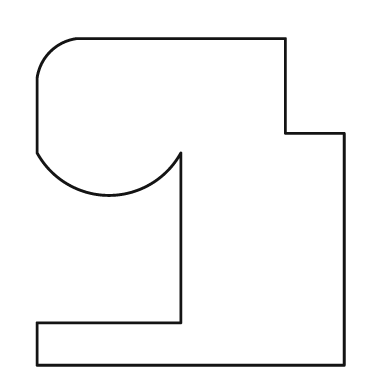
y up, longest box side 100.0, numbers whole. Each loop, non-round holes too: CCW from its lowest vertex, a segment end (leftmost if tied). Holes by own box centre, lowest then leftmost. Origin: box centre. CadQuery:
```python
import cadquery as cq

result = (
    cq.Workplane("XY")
    .moveTo(-47.0, -50.0)
    .lineTo(47.0, -50.0)
    .lineTo(47.0, 21.0)
    .lineTo(29.0, 21.0)
    .lineTo(29.0, 50.0)
    .lineTo(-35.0, 50.0)
    .threePointArc((-43.0, 46.0), (-47.0, 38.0))
    .lineTo(-47.0, 15.0)
    .threePointArc((-25.0, 2.0), (-3.0, 15.0))
    .lineTo(-3.0, -37.0)
    .lineTo(-47.0, -37.0)
    .close()
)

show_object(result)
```